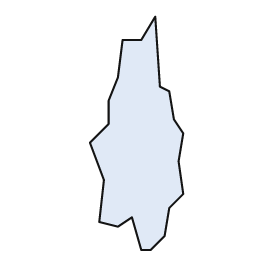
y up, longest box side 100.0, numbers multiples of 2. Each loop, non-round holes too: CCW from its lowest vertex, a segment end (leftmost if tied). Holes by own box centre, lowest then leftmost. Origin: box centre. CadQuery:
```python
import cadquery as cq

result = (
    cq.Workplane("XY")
    .moveTo(2.0, -50.0)
    .lineTo(6.0, -50.0)
    .lineTo(12.0, -44.0)
    .lineTo(14.0, -32.0)
    .lineTo(20.0, -26.0)
    .lineTo(18.0, -12.0)
    .lineTo(20.0, 0.0)
    .lineTo(16.0, 6.0)
    .lineTo(14.0, 18.0)
    .lineTo(10.0, 20.0)
    .lineTo(8.0, 50.0)
    .lineTo(2.0, 40.0)
    .lineTo(-6.0, 40.0)
    .lineTo(-8.0, 24.0)
    .lineTo(-12.0, 14.0)
    .lineTo(-12.0, 4.0)
    .lineTo(-20.0, -4.0)
    .lineTo(-14.0, -20.0)
    .lineTo(-16.0, -38.0)
    .lineTo(-8.0, -40.0)
    .lineTo(-2.0, -36.0)
    .close()
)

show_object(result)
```